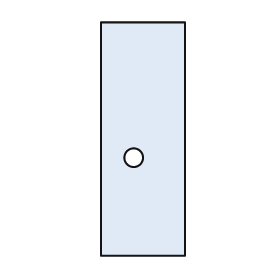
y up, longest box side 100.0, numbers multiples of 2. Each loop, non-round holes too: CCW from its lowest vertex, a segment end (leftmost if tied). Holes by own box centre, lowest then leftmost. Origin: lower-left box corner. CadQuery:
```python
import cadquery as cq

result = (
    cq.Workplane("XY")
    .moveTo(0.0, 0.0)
    .lineTo(36.0, 0.0)
    .lineTo(36.0, 100.0)
    .lineTo(0.0, 100.0)
    .close()
    .moveTo(14.0, 42.0)
    .circle(4.0)
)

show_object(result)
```